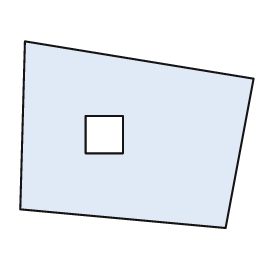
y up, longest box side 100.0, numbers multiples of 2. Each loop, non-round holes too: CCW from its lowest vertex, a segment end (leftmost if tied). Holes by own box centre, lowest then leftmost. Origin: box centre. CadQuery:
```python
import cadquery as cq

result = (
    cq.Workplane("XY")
    .moveTo(38.0, -40.0)
    .lineTo(50.0, 24.0)
    .lineTo(-48.0, 40.0)
    .lineTo(-50.0, -32.0)
    .close()
    .moveTo(-22.0, -8.0)
    .lineTo(-6.0, -8.0)
    .lineTo(-6.0, 8.0)
    .lineTo(-22.0, 8.0)
    .close()
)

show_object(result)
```